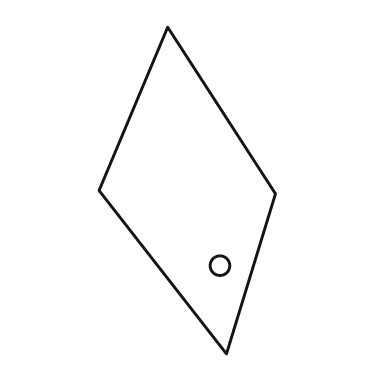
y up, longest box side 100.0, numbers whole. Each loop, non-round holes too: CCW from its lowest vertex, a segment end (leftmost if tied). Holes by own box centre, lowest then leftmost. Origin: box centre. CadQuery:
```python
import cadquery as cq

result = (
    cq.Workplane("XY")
    .moveTo(12.0, -50.0)
    .lineTo(27.0, -1.0)
    .lineTo(-6.0, 50.0)
    .lineTo(-27.0, 0.0)
    .close()
    .moveTo(10.0, -23.0)
    .circle(3.0)
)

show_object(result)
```